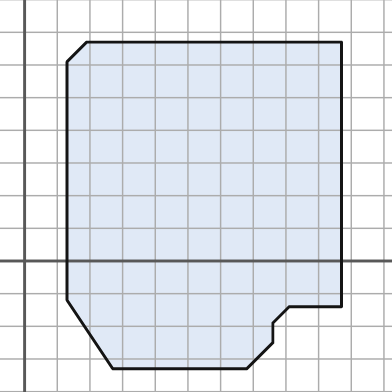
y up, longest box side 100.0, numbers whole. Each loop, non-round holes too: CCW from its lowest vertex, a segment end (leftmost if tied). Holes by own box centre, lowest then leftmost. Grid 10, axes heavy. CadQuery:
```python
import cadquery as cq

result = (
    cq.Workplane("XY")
    .moveTo(27.0, -33.0)
    .lineTo(68.0, -33.0)
    .lineTo(76.0, -25.0)
    .lineTo(76.0, -19.0)
    .lineTo(81.0, -14.0)
    .lineTo(97.0, -14.0)
    .lineTo(97.0, 67.0)
    .lineTo(19.0, 67.0)
    .lineTo(13.0, 61.0)
    .lineTo(13.0, -12.0)
    .close()
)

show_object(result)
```